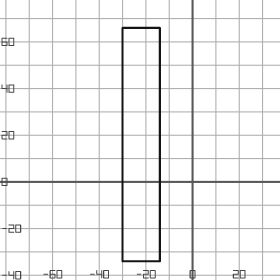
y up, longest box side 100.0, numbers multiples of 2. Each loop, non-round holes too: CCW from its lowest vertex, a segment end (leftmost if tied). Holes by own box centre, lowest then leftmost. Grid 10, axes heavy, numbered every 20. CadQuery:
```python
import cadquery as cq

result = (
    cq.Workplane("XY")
    .moveTo(-30.0, -34.0)
    .lineTo(-14.0, -34.0)
    .lineTo(-14.0, 66.0)
    .lineTo(-30.0, 66.0)
    .close()
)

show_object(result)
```